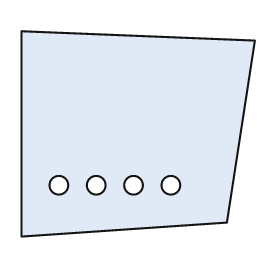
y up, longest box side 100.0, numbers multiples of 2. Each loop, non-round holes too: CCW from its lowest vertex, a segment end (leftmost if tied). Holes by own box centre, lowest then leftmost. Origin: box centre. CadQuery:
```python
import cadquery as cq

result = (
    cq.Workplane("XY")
    .moveTo(-50.0, -44.0)
    .lineTo(38.0, -38.0)
    .lineTo(50.0, 40.0)
    .lineTo(-50.0, 44.0)
    .close()
    .moveTo(-34.0, -22.0)
    .circle(4.0)
    .moveTo(-18.0, -22.0)
    .circle(4.0)
    .moveTo(-2.0, -22.0)
    .circle(4.0)
    .moveTo(14.0, -22.0)
    .circle(4.0)
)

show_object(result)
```